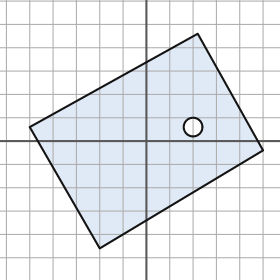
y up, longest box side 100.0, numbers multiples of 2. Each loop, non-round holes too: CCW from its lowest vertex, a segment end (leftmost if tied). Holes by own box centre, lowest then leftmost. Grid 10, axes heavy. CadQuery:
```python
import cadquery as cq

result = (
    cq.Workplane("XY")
    .moveTo(-20.0, -46.0)
    .lineTo(50.0, -4.0)
    .lineTo(22.0, 46.0)
    .lineTo(-50.0, 6.0)
    .close()
    .moveTo(20.0, 6.0)
    .circle(4.0)
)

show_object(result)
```